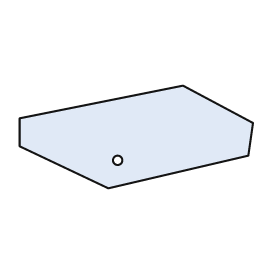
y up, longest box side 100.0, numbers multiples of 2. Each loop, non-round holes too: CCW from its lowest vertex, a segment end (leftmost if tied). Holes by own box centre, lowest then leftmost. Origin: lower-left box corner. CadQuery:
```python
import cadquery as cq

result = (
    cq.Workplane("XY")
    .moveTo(38.0, 0.0)
    .lineTo(98.0, 14.0)
    .lineTo(100.0, 28.0)
    .lineTo(70.0, 44.0)
    .lineTo(0.0, 30.0)
    .lineTo(0.0, 18.0)
    .close()
    .moveTo(42.0, 12.0)
    .circle(2.0)
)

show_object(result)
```